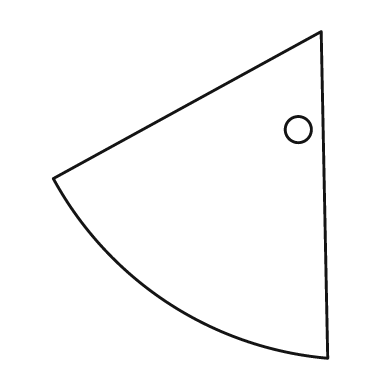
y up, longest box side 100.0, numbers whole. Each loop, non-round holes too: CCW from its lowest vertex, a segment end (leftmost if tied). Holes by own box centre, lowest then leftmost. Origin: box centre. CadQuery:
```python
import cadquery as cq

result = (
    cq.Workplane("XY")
    .moveTo(42.0, -50.0)
    .lineTo(40.0, 50.0)
    .lineTo(-42.0, 5.0)
    .threePointArc((-7.0, -33.0), (42.0, -50.0))
    .close()
    .moveTo(33.0, 20.0)
    .circle(4.0)
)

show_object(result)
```